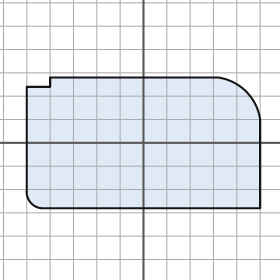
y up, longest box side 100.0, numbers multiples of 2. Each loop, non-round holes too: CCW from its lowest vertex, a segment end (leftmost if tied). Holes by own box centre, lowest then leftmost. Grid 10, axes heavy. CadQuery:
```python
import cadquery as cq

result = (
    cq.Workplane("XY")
    .moveTo(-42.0, -28.0)
    .lineTo(50.0, -28.0)
    .lineTo(50.0, 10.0)
    .threePointArc((44.0, 22.0), (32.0, 28.0))
    .lineTo(-40.0, 28.0)
    .lineTo(-40.0, 24.0)
    .lineTo(-50.0, 24.0)
    .lineTo(-50.0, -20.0)
    .threePointArc((-48.0, -26.0), (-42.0, -28.0))
    .close()
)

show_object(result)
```